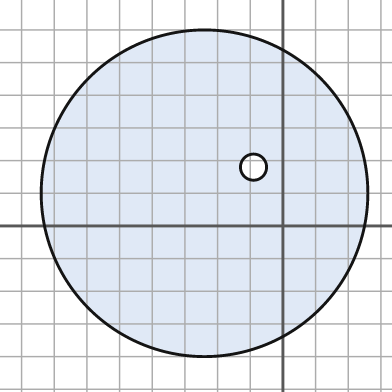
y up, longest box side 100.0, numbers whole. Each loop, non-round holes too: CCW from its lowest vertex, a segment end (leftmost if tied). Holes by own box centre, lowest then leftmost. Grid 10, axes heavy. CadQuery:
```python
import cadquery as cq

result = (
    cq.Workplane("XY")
    .moveTo(-24.0, 10.0)
    .circle(50.0)
    .moveTo(-9.0, 18.0)
    .circle(4.0)
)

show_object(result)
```